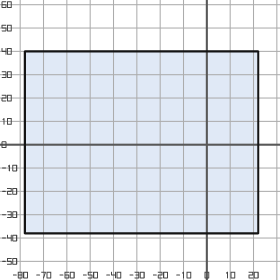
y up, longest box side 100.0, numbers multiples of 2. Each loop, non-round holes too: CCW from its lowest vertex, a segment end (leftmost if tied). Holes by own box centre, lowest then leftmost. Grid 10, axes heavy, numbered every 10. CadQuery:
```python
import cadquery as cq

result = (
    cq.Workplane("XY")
    .moveTo(-78.0, -38.0)
    .lineTo(22.0, -38.0)
    .lineTo(22.0, 40.0)
    .lineTo(-78.0, 40.0)
    .close()
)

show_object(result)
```